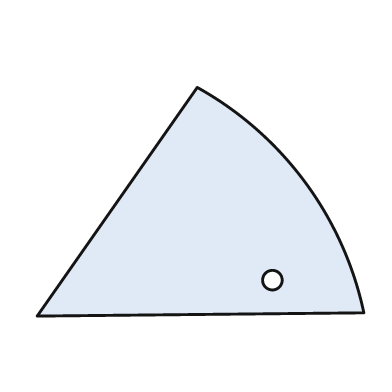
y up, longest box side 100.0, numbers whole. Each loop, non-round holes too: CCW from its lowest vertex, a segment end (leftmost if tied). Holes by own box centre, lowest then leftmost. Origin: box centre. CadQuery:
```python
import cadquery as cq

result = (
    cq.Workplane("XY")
    .moveTo(-50.0, -35.0)
    .lineTo(50.0, -34.0)
    .threePointArc((32.0, 6.0), (-1.0, 35.0))
    .close()
    .moveTo(22.0, -24.0)
    .circle(3.0)
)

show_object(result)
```